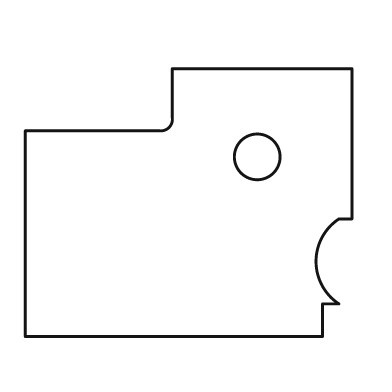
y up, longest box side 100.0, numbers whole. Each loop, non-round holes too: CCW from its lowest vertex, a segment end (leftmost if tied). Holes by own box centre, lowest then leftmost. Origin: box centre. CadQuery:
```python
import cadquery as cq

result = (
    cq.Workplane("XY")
    .moveTo(-50.0, -41.0)
    .lineTo(41.0, -41.0)
    .lineTo(41.0, -31.0)
    .lineTo(46.0, -31.0)
    .threePointArc((39.0, -18.0), (46.0, -5.0))
    .lineTo(50.0, -5.0)
    .lineTo(50.0, 41.0)
    .lineTo(-5.0, 41.0)
    .lineTo(-5.0, 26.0)
    .threePointArc((-6.0, 23.0), (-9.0, 22.0))
    .lineTo(-50.0, 22.0)
    .close()
    .moveTo(21.0, 14.0)
    .circle(7.0)
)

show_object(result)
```